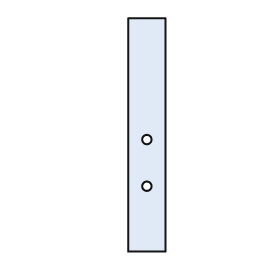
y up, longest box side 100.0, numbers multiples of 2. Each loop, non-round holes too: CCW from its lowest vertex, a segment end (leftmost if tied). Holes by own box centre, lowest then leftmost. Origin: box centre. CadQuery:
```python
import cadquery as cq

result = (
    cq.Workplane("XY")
    .moveTo(-8.0, -50.0)
    .lineTo(8.0, -50.0)
    .lineTo(8.0, 50.0)
    .lineTo(-8.0, 50.0)
    .close()
    .moveTo(0.0, -22.0)
    .circle(2.0)
    .moveTo(0.0, -2.0)
    .circle(2.0)
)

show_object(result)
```